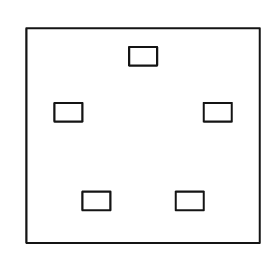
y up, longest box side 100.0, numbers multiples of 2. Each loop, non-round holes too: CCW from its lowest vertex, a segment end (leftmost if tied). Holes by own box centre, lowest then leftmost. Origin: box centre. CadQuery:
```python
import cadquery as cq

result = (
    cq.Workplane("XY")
    .moveTo(-50.0, -46.0)
    .lineTo(50.0, -46.0)
    .lineTo(50.0, 46.0)
    .lineTo(-50.0, 46.0)
    .close()
    .moveTo(-26.0, -32.0)
    .lineTo(-14.0, -32.0)
    .lineTo(-14.0, -24.0)
    .lineTo(-26.0, -24.0)
    .close()
    .moveTo(14.0, -32.0)
    .lineTo(26.0, -32.0)
    .lineTo(26.0, -24.0)
    .lineTo(14.0, -24.0)
    .close()
    .moveTo(-38.0, 6.0)
    .lineTo(-26.0, 6.0)
    .lineTo(-26.0, 14.0)
    .lineTo(-38.0, 14.0)
    .close()
    .moveTo(26.0, 6.0)
    .lineTo(38.0, 6.0)
    .lineTo(38.0, 14.0)
    .lineTo(26.0, 14.0)
    .close()
    .moveTo(-6.0, 30.0)
    .lineTo(6.0, 30.0)
    .lineTo(6.0, 38.0)
    .lineTo(-6.0, 38.0)
    .close()
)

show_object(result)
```